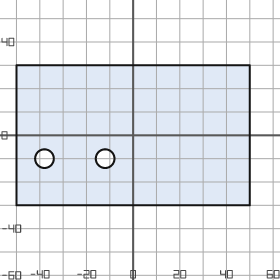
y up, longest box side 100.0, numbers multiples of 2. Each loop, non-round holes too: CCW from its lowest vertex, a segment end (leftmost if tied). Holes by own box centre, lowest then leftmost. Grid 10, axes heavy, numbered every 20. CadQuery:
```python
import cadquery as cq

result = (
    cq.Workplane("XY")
    .moveTo(-50.0, -30.0)
    .lineTo(50.0, -30.0)
    .lineTo(50.0, 30.0)
    .lineTo(-50.0, 30.0)
    .close()
    .moveTo(-38.0, -10.0)
    .circle(4.0)
    .moveTo(-12.0, -10.0)
    .circle(4.0)
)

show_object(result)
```